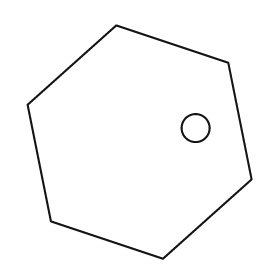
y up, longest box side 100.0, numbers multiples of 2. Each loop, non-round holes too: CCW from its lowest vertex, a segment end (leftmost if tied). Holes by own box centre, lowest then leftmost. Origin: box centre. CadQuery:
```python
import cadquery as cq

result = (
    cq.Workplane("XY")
    .moveTo(10.0, -50.0)
    .lineTo(48.0, -16.0)
    .lineTo(38.0, 34.0)
    .lineTo(-10.0, 50.0)
    .lineTo(-48.0, 16.0)
    .lineTo(-38.0, -34.0)
    .close()
    .moveTo(24.0, 6.0)
    .circle(6.0)
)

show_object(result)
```